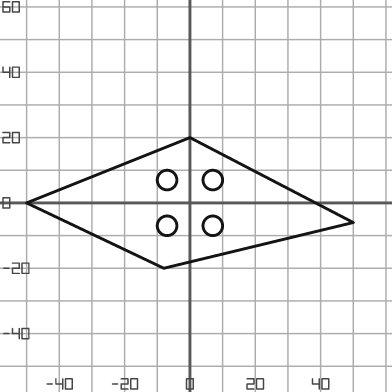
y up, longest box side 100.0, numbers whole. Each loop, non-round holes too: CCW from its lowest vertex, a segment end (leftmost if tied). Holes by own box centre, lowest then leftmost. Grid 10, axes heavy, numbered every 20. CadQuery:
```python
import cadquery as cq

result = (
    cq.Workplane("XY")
    .moveTo(-8.0, -20.0)
    .lineTo(50.0, -6.0)
    .lineTo(0.0, 20.0)
    .lineTo(-50.0, 0.0)
    .close()
    .moveTo(-7.0, -7.0)
    .circle(3.0)
    .moveTo(7.0, -7.0)
    .circle(3.0)
    .moveTo(-7.0, 7.0)
    .circle(3.0)
    .moveTo(7.0, 7.0)
    .circle(3.0)
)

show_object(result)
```